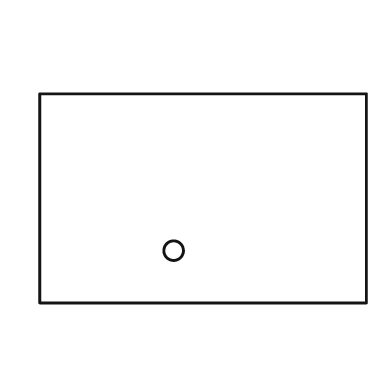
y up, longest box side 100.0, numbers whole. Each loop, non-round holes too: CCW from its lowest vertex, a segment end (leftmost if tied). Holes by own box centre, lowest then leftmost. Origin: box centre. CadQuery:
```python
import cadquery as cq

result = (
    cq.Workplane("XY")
    .moveTo(-50.0, -32.0)
    .lineTo(50.0, -32.0)
    .lineTo(50.0, 32.0)
    .lineTo(-50.0, 32.0)
    .close()
    .moveTo(-9.0, -16.0)
    .circle(3.0)
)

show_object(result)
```